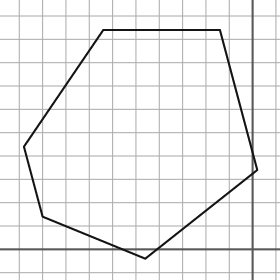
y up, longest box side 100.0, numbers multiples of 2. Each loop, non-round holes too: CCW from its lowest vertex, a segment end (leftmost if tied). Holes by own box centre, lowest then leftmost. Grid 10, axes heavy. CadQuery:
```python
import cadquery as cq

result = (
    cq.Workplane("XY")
    .moveTo(-46.0, -4.0)
    .lineTo(2.0, 34.0)
    .lineTo(-14.0, 94.0)
    .lineTo(-64.0, 94.0)
    .lineTo(-98.0, 44.0)
    .lineTo(-90.0, 14.0)
    .close()
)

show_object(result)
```